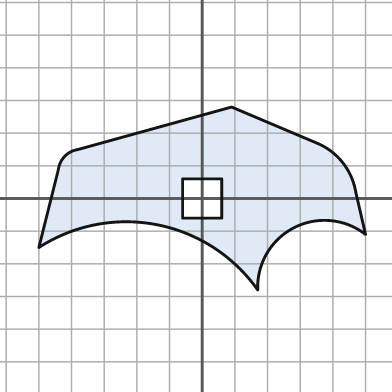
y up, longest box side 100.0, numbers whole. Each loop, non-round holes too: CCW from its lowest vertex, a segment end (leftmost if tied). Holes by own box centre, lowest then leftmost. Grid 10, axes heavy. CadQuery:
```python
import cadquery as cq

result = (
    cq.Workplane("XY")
    .moveTo(17.0, -28.0)
    .threePointArc((28.0, -9.0), (50.0, -11.0))
    .lineTo(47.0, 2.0)
    .threePointArc((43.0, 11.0), (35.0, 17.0))
    .lineTo(9.0, 28.0)
    .lineTo(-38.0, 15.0)
    .threePointArc((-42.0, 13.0), (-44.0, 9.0))
    .lineTo(-50.0, -15.0)
    .threePointArc((-14.0, -8.0), (17.0, -28.0))
    .close()
    .moveTo(-6.0, -6.0)
    .lineTo(6.0, -6.0)
    .lineTo(6.0, 6.0)
    .lineTo(-6.0, 6.0)
    .close()
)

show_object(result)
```